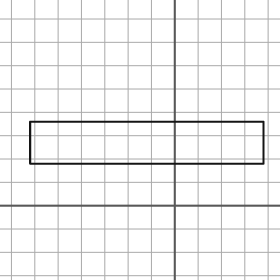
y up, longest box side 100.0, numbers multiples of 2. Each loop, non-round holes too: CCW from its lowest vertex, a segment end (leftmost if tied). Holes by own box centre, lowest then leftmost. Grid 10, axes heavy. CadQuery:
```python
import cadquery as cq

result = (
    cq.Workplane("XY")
    .moveTo(-62.0, 18.0)
    .lineTo(38.0, 18.0)
    .lineTo(38.0, 36.0)
    .lineTo(-62.0, 36.0)
    .close()
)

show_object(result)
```